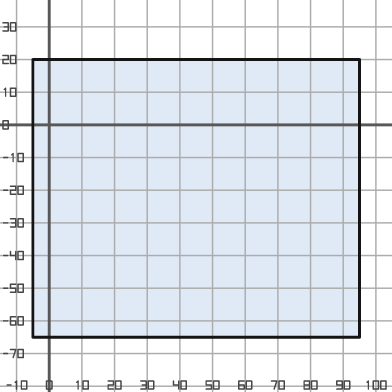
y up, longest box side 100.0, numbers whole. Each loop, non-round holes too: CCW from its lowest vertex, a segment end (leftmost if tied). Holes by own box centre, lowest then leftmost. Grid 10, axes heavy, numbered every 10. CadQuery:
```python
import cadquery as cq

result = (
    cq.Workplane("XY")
    .moveTo(-5.0, -65.0)
    .lineTo(95.0, -65.0)
    .lineTo(95.0, 20.0)
    .lineTo(-5.0, 20.0)
    .close()
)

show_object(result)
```